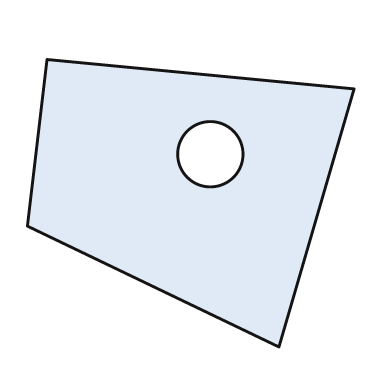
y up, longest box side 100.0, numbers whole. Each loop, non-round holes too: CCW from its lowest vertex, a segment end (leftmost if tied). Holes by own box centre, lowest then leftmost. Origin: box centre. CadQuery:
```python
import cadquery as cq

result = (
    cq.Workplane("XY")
    .moveTo(27.0, -44.0)
    .lineTo(50.0, 35.0)
    .lineTo(-44.0, 44.0)
    .lineTo(-50.0, -7.0)
    .close()
    .moveTo(6.0, 15.0)
    .circle(10.0)
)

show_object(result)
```